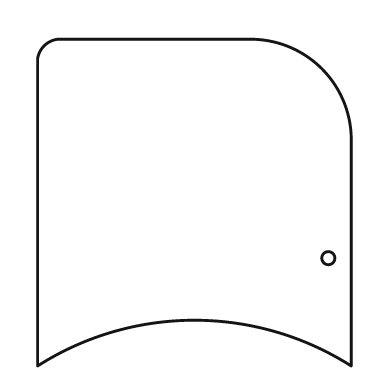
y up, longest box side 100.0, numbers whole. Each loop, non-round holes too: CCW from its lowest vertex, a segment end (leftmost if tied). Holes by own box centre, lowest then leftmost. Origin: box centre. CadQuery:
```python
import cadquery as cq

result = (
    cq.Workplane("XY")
    .moveTo(-48.0, -50.0)
    .threePointArc((0.0, -36.0), (48.0, -50.0))
    .lineTo(48.0, 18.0)
    .threePointArc((39.0, 41.0), (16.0, 50.0))
    .lineTo(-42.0, 50.0)
    .threePointArc((-46.0, 48.0), (-48.0, 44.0))
    .close()
    .moveTo(41.0, -17.0)
    .circle(2.0)
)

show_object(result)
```